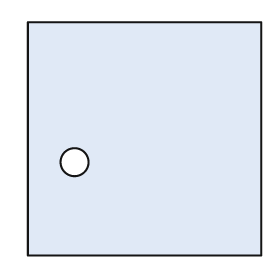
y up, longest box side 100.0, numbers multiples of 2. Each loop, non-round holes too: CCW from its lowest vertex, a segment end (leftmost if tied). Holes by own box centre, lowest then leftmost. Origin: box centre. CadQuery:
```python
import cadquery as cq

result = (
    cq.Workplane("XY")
    .moveTo(-50.0, -50.0)
    .lineTo(50.0, -50.0)
    .lineTo(50.0, 50.0)
    .lineTo(-50.0, 50.0)
    .close()
    .moveTo(-30.0, -10.0)
    .circle(6.0)
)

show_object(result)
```